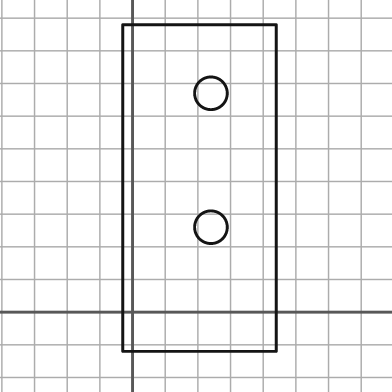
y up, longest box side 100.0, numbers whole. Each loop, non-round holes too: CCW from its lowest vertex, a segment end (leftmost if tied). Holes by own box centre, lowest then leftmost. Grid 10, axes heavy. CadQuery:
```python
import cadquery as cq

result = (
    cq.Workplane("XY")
    .moveTo(-3.0, -12.0)
    .lineTo(44.0, -12.0)
    .lineTo(44.0, 88.0)
    .lineTo(-3.0, 88.0)
    .close()
    .moveTo(24.0, 26.0)
    .circle(5.0)
    .moveTo(24.0, 67.0)
    .circle(5.0)
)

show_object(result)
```